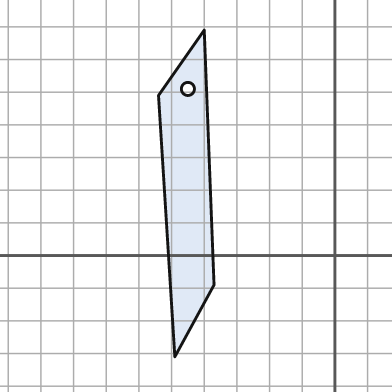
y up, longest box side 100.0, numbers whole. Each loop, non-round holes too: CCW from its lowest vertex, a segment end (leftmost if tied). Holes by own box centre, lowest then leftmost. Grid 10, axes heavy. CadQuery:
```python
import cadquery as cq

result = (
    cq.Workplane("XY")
    .moveTo(-49.0, -31.0)
    .lineTo(-37.0, -9.0)
    .lineTo(-40.0, 69.0)
    .lineTo(-54.0, 49.0)
    .close()
    .moveTo(-45.0, 51.0)
    .circle(2.0)
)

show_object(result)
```